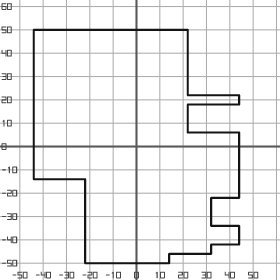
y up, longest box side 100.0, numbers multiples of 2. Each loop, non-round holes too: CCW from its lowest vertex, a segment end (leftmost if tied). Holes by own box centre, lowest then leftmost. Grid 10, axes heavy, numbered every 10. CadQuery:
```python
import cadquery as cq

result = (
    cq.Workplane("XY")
    .moveTo(-22.0, -50.0)
    .lineTo(14.0, -50.0)
    .lineTo(14.0, -46.0)
    .lineTo(32.0, -46.0)
    .lineTo(32.0, -42.0)
    .lineTo(44.0, -42.0)
    .lineTo(44.0, -34.0)
    .lineTo(32.0, -34.0)
    .lineTo(32.0, -22.0)
    .lineTo(44.0, -22.0)
    .lineTo(44.0, 6.0)
    .lineTo(22.0, 6.0)
    .lineTo(22.0, 18.0)
    .lineTo(44.0, 18.0)
    .lineTo(44.0, 22.0)
    .lineTo(22.0, 22.0)
    .lineTo(22.0, 50.0)
    .lineTo(-44.0, 50.0)
    .lineTo(-44.0, -14.0)
    .lineTo(-22.0, -14.0)
    .close()
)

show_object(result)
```